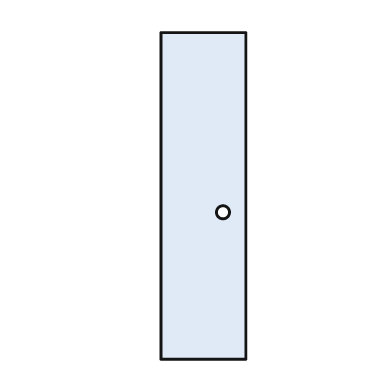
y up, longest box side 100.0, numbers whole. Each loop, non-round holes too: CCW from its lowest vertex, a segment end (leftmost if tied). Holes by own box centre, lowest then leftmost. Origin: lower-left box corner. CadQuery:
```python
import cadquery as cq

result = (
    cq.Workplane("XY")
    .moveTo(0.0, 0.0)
    .lineTo(26.0, 0.0)
    .lineTo(26.0, 100.0)
    .lineTo(0.0, 100.0)
    .close()
    .moveTo(19.0, 45.0)
    .circle(2.0)
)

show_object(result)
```